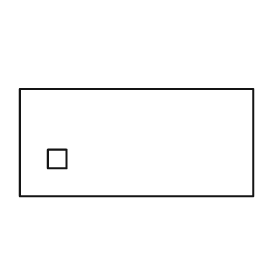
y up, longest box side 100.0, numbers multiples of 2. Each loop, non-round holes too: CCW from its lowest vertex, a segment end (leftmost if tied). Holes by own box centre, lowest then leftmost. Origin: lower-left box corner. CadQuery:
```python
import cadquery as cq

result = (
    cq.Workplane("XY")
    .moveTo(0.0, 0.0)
    .lineTo(100.0, 0.0)
    .lineTo(100.0, 46.0)
    .lineTo(0.0, 46.0)
    .close()
    .moveTo(12.0, 12.0)
    .lineTo(20.0, 12.0)
    .lineTo(20.0, 20.0)
    .lineTo(12.0, 20.0)
    .close()
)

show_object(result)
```